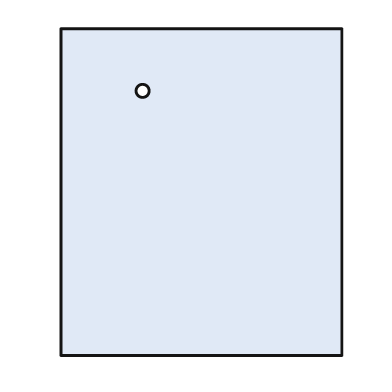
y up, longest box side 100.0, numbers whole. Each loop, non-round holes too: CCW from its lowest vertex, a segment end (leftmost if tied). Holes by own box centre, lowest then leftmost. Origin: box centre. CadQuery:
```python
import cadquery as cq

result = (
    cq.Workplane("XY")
    .moveTo(-43.0, -50.0)
    .lineTo(43.0, -50.0)
    .lineTo(43.0, 50.0)
    .lineTo(-43.0, 50.0)
    .close()
    .moveTo(-18.0, 31.0)
    .circle(2.0)
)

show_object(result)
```